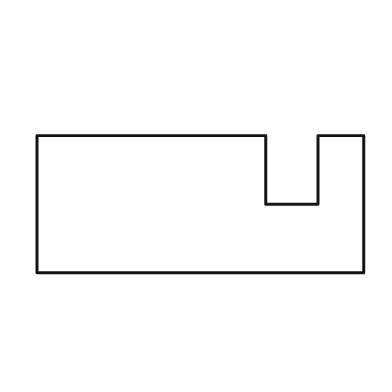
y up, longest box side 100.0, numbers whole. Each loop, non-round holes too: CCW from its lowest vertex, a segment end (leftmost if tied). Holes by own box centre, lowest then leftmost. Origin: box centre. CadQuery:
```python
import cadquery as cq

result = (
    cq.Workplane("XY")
    .moveTo(-50.0, -21.0)
    .lineTo(50.0, -21.0)
    .lineTo(50.0, 21.0)
    .lineTo(36.0, 21.0)
    .lineTo(36.0, 0.0)
    .lineTo(20.0, 0.0)
    .lineTo(20.0, 21.0)
    .lineTo(-50.0, 21.0)
    .close()
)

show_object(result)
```